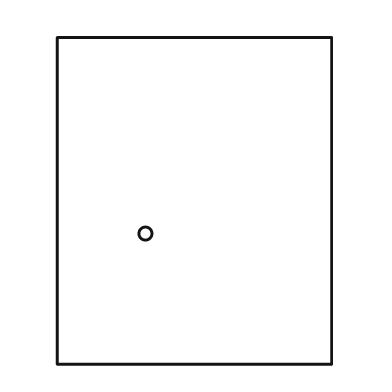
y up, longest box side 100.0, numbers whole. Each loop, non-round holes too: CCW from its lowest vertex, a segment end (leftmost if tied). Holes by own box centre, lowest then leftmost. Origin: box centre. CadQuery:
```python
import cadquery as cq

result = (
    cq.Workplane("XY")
    .moveTo(-42.0, -50.0)
    .lineTo(42.0, -50.0)
    .lineTo(42.0, 50.0)
    .lineTo(-42.0, 50.0)
    .close()
    .moveTo(-15.0, -10.0)
    .circle(2.0)
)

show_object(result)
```